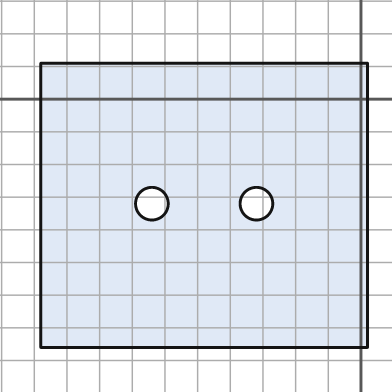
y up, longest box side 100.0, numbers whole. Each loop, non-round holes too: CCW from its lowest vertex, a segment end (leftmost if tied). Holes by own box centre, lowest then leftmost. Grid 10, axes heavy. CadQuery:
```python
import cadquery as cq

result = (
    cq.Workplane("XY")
    .moveTo(-98.0, -76.0)
    .lineTo(2.0, -76.0)
    .lineTo(2.0, 11.0)
    .lineTo(-98.0, 11.0)
    .close()
    .moveTo(-64.0, -32.0)
    .circle(5.0)
    .moveTo(-32.0, -32.0)
    .circle(5.0)
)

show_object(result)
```